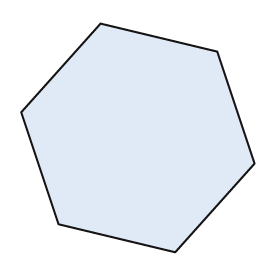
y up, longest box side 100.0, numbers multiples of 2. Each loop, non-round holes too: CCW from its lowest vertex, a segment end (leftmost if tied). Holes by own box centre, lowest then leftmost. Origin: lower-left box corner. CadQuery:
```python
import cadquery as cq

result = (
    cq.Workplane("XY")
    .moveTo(66.0, 0.0)
    .lineTo(100.0, 38.0)
    .lineTo(84.0, 86.0)
    .lineTo(34.0, 98.0)
    .lineTo(0.0, 60.0)
    .lineTo(16.0, 12.0)
    .close()
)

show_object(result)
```